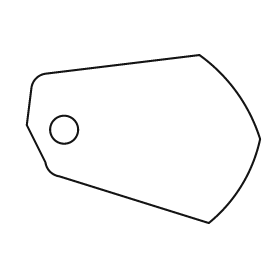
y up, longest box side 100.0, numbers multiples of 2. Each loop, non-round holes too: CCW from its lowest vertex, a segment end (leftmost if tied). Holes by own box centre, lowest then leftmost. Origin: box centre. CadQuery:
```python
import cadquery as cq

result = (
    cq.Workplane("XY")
    .moveTo(28.0, -36.0)
    .threePointArc((42.0, -20.0), (50.0, 0.0))
    .threePointArc((40.0, 20.0), (24.0, 36.0))
    .lineTo(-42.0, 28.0)
    .threePointArc((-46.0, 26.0), (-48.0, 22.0))
    .lineTo(-50.0, 6.0)
    .lineTo(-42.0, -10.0)
    .threePointArc((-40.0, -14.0), (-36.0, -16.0))
    .close()
    .moveTo(-34.0, 4.0)
    .circle(6.0)
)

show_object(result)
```